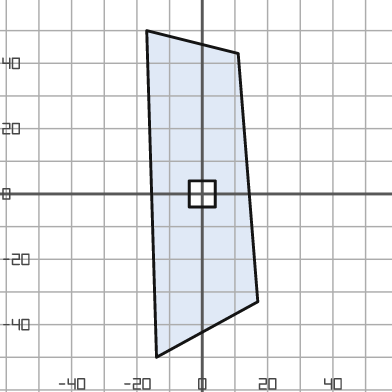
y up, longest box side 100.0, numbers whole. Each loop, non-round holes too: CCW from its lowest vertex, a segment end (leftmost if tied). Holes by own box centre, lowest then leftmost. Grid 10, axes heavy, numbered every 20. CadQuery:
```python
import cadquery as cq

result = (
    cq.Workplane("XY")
    .moveTo(-14.0, -50.0)
    .lineTo(17.0, -33.0)
    .lineTo(11.0, 43.0)
    .lineTo(-17.0, 50.0)
    .close()
    .moveTo(-4.0, -4.0)
    .lineTo(4.0, -4.0)
    .lineTo(4.0, 4.0)
    .lineTo(-4.0, 4.0)
    .close()
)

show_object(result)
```